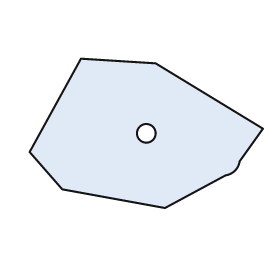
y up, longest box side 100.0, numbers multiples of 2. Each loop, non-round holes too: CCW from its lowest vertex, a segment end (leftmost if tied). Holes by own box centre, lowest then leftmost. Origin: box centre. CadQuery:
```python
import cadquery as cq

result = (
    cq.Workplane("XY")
    .moveTo(8.0, -32.0)
    .lineTo(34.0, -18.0)
    .threePointArc((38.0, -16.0), (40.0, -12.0))
    .lineTo(50.0, 2.0)
    .lineTo(4.0, 30.0)
    .lineTo(-28.0, 32.0)
    .lineTo(-50.0, -8.0)
    .lineTo(-36.0, -24.0)
    .close()
    .moveTo(0.0, 0.0)
    .circle(4.0)
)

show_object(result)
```